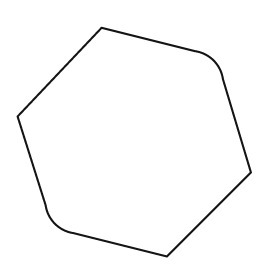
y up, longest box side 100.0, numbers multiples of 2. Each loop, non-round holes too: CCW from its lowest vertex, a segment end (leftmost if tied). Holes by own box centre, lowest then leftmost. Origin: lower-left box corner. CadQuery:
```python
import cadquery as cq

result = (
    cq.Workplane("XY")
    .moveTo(64.0, 0.0)
    .lineTo(100.0, 36.0)
    .lineTo(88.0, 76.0)
    .threePointArc((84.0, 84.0), (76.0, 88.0))
    .lineTo(36.0, 98.0)
    .lineTo(0.0, 60.0)
    .lineTo(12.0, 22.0)
    .threePointArc((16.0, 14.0), (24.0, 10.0))
    .close()
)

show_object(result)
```